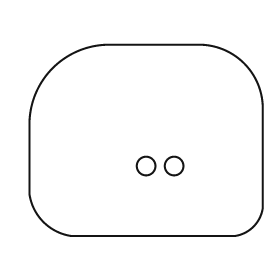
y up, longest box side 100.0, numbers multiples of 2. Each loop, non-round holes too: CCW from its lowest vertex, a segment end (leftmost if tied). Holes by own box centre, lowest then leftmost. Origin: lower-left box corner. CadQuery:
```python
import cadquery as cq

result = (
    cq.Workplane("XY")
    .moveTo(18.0, 0.0)
    .lineTo(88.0, 0.0)
    .threePointArc((96.0, 4.0), (100.0, 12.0))
    .lineTo(100.0, 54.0)
    .threePointArc((92.0, 74.0), (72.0, 82.0))
    .lineTo(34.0, 82.0)
    .threePointArc((10.0, 72.0), (0.0, 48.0))
    .lineTo(0.0, 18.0)
    .threePointArc((6.0, 6.0), (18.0, 0.0))
    .close()
    .moveTo(50.0, 30.0)
    .circle(4.0)
    .moveTo(62.0, 30.0)
    .circle(4.0)
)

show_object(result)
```